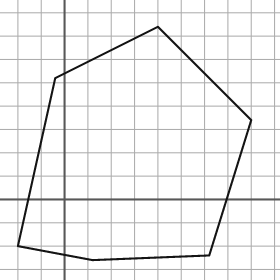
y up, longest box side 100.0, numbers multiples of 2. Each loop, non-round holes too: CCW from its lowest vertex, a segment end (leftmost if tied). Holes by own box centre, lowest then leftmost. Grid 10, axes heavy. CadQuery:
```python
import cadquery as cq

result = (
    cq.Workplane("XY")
    .moveTo(12.0, -26.0)
    .lineTo(62.0, -24.0)
    .lineTo(80.0, 34.0)
    .lineTo(40.0, 74.0)
    .lineTo(-4.0, 52.0)
    .lineTo(-20.0, -20.0)
    .close()
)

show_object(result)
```